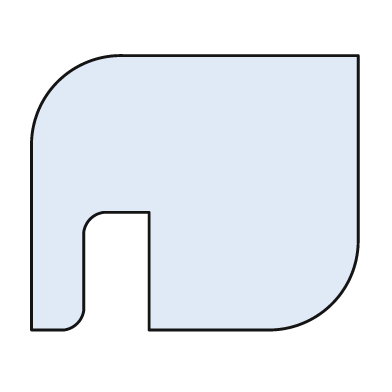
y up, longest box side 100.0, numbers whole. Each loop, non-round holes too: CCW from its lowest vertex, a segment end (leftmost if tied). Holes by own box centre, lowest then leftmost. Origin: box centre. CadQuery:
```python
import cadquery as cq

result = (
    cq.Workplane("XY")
    .moveTo(-50.0, -42.0)
    .lineTo(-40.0, -42.0)
    .threePointArc((-36.0, -40.0), (-34.0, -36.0))
    .lineTo(-34.0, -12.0)
    .threePointArc((-32.0, -8.0), (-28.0, -6.0))
    .lineTo(-14.0, -6.0)
    .lineTo(-14.0, -42.0)
    .lineTo(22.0, -42.0)
    .threePointArc((42.0, -34.0), (50.0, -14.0))
    .lineTo(50.0, 42.0)
    .lineTo(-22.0, 42.0)
    .threePointArc((-42.0, 34.0), (-50.0, 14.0))
    .close()
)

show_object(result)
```